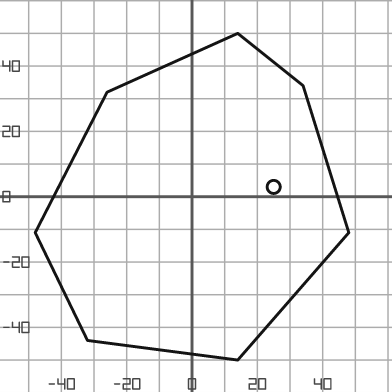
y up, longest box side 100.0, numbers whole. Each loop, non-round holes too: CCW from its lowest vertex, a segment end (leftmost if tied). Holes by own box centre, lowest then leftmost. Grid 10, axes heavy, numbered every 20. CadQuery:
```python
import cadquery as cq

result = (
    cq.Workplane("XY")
    .moveTo(14.0, -50.0)
    .lineTo(48.0, -11.0)
    .lineTo(34.0, 34.0)
    .lineTo(14.0, 50.0)
    .lineTo(-26.0, 32.0)
    .lineTo(-48.0, -11.0)
    .lineTo(-32.0, -44.0)
    .close()
    .moveTo(25.0, 3.0)
    .circle(2.0)
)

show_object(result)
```